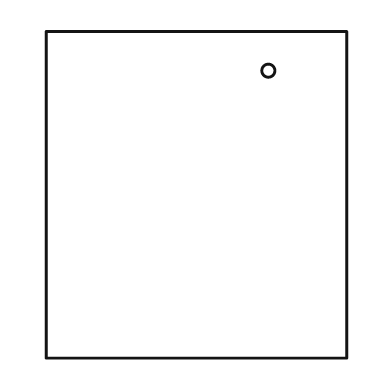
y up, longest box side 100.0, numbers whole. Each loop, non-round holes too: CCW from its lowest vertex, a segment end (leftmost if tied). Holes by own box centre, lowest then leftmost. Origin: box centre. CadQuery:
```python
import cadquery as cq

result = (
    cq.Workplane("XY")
    .moveTo(-46.0, -50.0)
    .lineTo(46.0, -50.0)
    .lineTo(46.0, 50.0)
    .lineTo(-46.0, 50.0)
    .close()
    .moveTo(22.0, 38.0)
    .circle(2.0)
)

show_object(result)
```